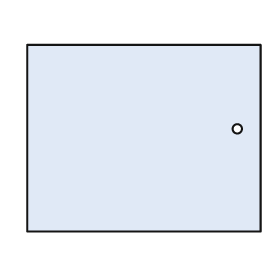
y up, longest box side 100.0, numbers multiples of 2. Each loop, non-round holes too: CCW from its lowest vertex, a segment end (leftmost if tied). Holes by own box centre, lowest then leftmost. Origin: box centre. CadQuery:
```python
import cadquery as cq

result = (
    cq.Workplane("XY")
    .moveTo(-50.0, -40.0)
    .lineTo(50.0, -40.0)
    .lineTo(50.0, 40.0)
    .lineTo(-50.0, 40.0)
    .close()
    .moveTo(40.0, 4.0)
    .circle(2.0)
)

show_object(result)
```